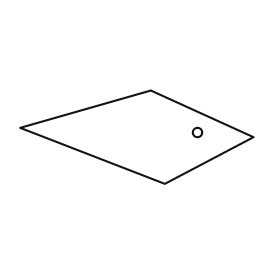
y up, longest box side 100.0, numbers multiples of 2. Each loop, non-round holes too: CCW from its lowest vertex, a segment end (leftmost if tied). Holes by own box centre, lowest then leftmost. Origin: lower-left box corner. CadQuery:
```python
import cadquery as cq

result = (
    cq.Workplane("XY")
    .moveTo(62.0, 0.0)
    .lineTo(100.0, 20.0)
    .lineTo(56.0, 40.0)
    .lineTo(0.0, 24.0)
    .close()
    .moveTo(76.0, 22.0)
    .circle(2.0)
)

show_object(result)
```